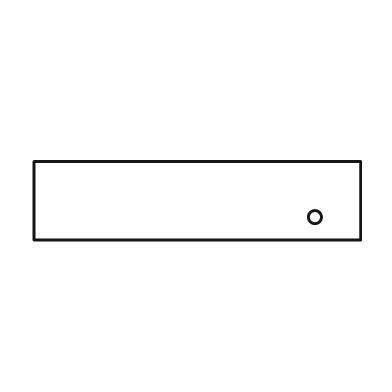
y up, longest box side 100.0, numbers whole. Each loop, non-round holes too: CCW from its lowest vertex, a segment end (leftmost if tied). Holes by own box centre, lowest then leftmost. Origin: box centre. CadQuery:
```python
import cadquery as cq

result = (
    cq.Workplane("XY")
    .moveTo(-50.0, -12.0)
    .lineTo(50.0, -12.0)
    .lineTo(50.0, 12.0)
    .lineTo(-50.0, 12.0)
    .close()
    .moveTo(36.0, -5.0)
    .circle(2.0)
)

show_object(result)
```